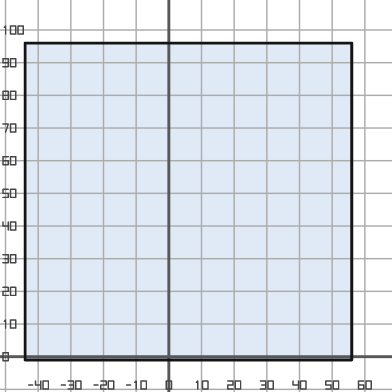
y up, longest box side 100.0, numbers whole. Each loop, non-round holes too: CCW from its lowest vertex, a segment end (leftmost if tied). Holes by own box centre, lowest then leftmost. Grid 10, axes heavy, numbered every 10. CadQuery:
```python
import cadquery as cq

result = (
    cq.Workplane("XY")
    .moveTo(-44.0, -1.0)
    .lineTo(56.0, -1.0)
    .lineTo(56.0, 96.0)
    .lineTo(-44.0, 96.0)
    .close()
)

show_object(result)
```